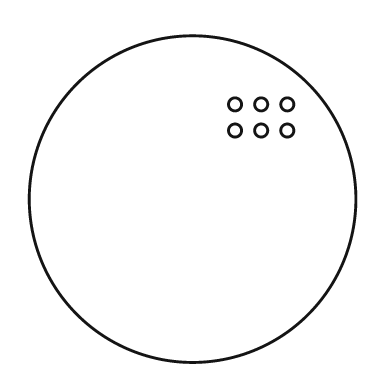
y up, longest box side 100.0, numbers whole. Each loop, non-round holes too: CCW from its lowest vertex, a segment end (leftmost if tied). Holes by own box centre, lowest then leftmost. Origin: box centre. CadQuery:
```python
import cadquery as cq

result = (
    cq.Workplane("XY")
    .moveTo(0.0, 0.0)
    .circle(50.0)
    .moveTo(13.0, 21.0)
    .circle(2.0)
    .moveTo(21.0, 21.0)
    .circle(2.0)
    .moveTo(29.0, 21.0)
    .circle(2.0)
    .moveTo(13.0, 29.0)
    .circle(2.0)
    .moveTo(21.0, 29.0)
    .circle(2.0)
    .moveTo(29.0, 29.0)
    .circle(2.0)
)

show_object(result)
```